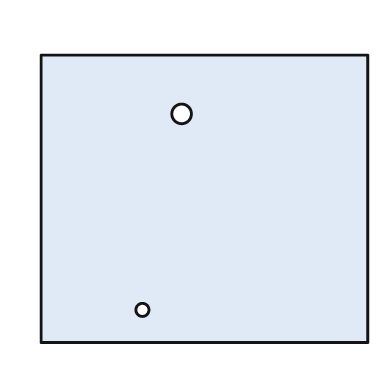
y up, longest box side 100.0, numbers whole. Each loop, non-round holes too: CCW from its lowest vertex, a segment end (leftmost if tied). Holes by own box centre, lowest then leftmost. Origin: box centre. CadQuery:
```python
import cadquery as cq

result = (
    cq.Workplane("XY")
    .moveTo(-50.0, -44.0)
    .lineTo(50.0, -44.0)
    .lineTo(50.0, 44.0)
    .lineTo(-50.0, 44.0)
    .close()
    .moveTo(-19.0, -34.0)
    .circle(2.0)
    .moveTo(-7.0, 26.0)
    .circle(3.0)
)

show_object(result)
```